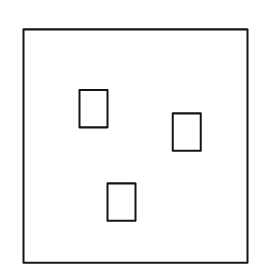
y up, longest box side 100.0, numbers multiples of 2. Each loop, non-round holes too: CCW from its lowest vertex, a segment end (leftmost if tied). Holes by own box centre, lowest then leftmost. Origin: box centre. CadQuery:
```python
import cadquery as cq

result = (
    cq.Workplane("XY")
    .moveTo(-48.0, -50.0)
    .lineTo(48.0, -50.0)
    .lineTo(48.0, 50.0)
    .lineTo(-48.0, 50.0)
    .close()
    .moveTo(-12.0, -32.0)
    .lineTo(0.0, -32.0)
    .lineTo(0.0, -16.0)
    .lineTo(-12.0, -16.0)
    .close()
    .moveTo(16.0, -2.0)
    .lineTo(28.0, -2.0)
    .lineTo(28.0, 14.0)
    .lineTo(16.0, 14.0)
    .close()
    .moveTo(-24.0, 8.0)
    .lineTo(-12.0, 8.0)
    .lineTo(-12.0, 24.0)
    .lineTo(-24.0, 24.0)
    .close()
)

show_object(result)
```